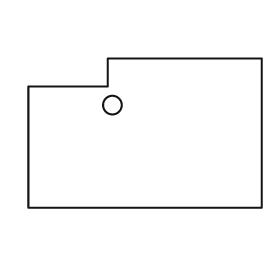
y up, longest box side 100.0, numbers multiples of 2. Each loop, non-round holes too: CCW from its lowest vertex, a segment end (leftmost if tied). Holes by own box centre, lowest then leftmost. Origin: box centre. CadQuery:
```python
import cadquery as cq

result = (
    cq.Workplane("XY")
    .moveTo(-50.0, -32.0)
    .lineTo(50.0, -32.0)
    .lineTo(50.0, 32.0)
    .lineTo(-16.0, 32.0)
    .lineTo(-16.0, 20.0)
    .lineTo(-50.0, 20.0)
    .close()
    .moveTo(-14.0, 12.0)
    .circle(4.0)
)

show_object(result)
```